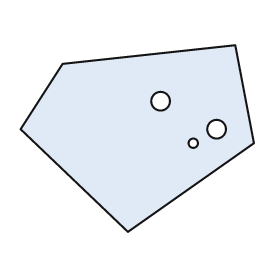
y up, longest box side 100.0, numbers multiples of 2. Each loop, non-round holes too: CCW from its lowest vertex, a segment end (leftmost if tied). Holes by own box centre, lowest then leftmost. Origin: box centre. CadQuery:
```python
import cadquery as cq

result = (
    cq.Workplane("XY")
    .moveTo(-4.0, -40.0)
    .lineTo(50.0, -2.0)
    .lineTo(42.0, 40.0)
    .lineTo(-32.0, 32.0)
    .lineTo(-50.0, 4.0)
    .close()
    .moveTo(24.0, -2.0)
    .circle(2.0)
    .moveTo(34.0, 4.0)
    .circle(4.0)
    .moveTo(10.0, 16.0)
    .circle(4.0)
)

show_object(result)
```